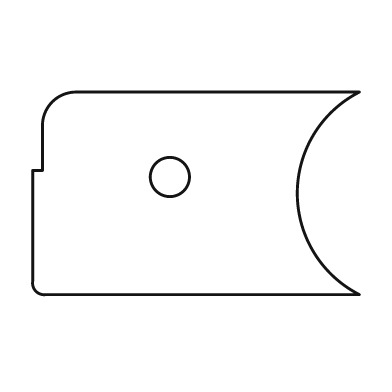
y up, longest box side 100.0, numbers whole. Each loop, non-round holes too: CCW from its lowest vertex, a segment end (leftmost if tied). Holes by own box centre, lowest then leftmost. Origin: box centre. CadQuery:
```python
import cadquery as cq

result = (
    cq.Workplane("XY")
    .moveTo(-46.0, -31.0)
    .lineTo(50.0, -31.0)
    .threePointArc((31.0, 0.0), (50.0, 31.0))
    .lineTo(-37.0, 31.0)
    .threePointArc((-44.0, 28.0), (-47.0, 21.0))
    .lineTo(-47.0, 7.0)
    .lineTo(-50.0, 7.0)
    .lineTo(-50.0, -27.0)
    .threePointArc((-49.0, -30.0), (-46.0, -31.0))
    .close()
    .moveTo(-8.0, 5.0)
    .circle(6.0)
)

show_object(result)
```